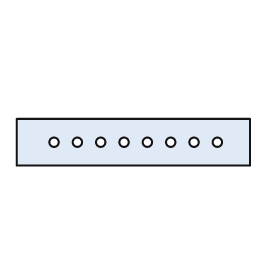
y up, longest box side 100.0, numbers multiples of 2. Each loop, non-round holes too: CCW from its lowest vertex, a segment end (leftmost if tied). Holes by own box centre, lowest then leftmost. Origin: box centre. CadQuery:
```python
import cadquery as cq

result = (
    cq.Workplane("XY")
    .moveTo(-50.0, -10.0)
    .lineTo(50.0, -10.0)
    .lineTo(50.0, 10.0)
    .lineTo(-50.0, 10.0)
    .close()
    .moveTo(-34.0, 0.0)
    .circle(2.0)
    .moveTo(-24.0, 0.0)
    .circle(2.0)
    .moveTo(-14.0, 0.0)
    .circle(2.0)
    .moveTo(-4.0, 0.0)
    .circle(2.0)
    .moveTo(6.0, 0.0)
    .circle(2.0)
    .moveTo(16.0, 0.0)
    .circle(2.0)
    .moveTo(26.0, 0.0)
    .circle(2.0)
    .moveTo(36.0, 0.0)
    .circle(2.0)
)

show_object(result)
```